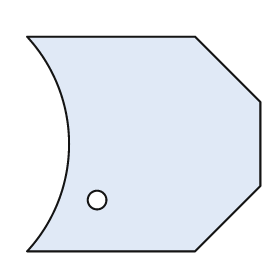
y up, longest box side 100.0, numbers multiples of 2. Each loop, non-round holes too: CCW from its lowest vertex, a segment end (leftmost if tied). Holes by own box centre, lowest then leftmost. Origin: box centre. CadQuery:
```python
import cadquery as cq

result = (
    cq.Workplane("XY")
    .moveTo(-50.0, -46.0)
    .lineTo(22.0, -46.0)
    .lineTo(50.0, -18.0)
    .lineTo(50.0, 18.0)
    .lineTo(22.0, 46.0)
    .lineTo(-50.0, 46.0)
    .threePointArc((-32.0, 0.0), (-50.0, -46.0))
    .close()
    .moveTo(-20.0, -24.0)
    .circle(4.0)
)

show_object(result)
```